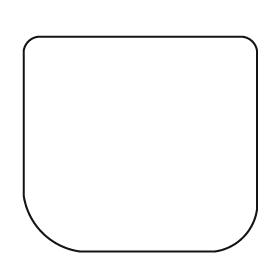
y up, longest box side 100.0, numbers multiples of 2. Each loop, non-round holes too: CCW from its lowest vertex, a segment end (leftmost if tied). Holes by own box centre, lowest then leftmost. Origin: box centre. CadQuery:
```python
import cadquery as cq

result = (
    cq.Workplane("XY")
    .moveTo(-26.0, -46.0)
    .lineTo(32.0, -46.0)
    .threePointArc((44.0, -40.0), (50.0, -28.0))
    .lineTo(50.0, 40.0)
    .threePointArc((48.0, 44.0), (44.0, 46.0))
    .lineTo(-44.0, 46.0)
    .threePointArc((-48.0, 44.0), (-50.0, 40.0))
    .lineTo(-50.0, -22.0)
    .threePointArc((-42.0, -38.0), (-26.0, -46.0))
    .close()
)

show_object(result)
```